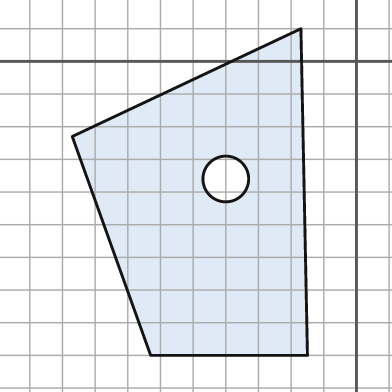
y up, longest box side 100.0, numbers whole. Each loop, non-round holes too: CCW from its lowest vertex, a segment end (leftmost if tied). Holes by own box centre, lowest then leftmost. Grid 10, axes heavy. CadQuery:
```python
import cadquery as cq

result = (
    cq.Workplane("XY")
    .moveTo(-63.0, -90.0)
    .lineTo(-15.0, -90.0)
    .lineTo(-17.0, 10.0)
    .lineTo(-87.0, -23.0)
    .close()
    .moveTo(-40.0, -36.0)
    .circle(7.0)
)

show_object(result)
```